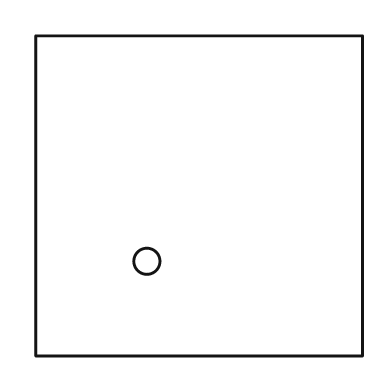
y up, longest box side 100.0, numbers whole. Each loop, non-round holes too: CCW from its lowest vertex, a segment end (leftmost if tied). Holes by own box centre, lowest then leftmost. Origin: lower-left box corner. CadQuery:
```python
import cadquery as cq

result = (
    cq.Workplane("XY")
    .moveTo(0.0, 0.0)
    .lineTo(100.0, 0.0)
    .lineTo(100.0, 98.0)
    .lineTo(0.0, 98.0)
    .close()
    .moveTo(34.0, 29.0)
    .circle(4.0)
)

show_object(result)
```